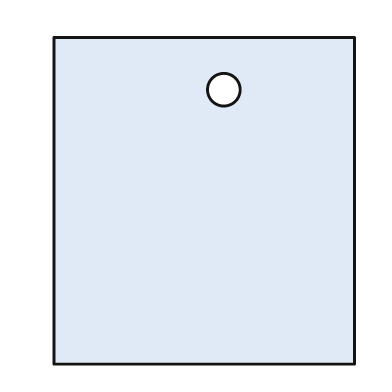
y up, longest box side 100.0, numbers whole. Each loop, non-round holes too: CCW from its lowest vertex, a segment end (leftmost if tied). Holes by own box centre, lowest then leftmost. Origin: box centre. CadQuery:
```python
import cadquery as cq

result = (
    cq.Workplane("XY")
    .moveTo(-46.0, -50.0)
    .lineTo(46.0, -50.0)
    .lineTo(46.0, 50.0)
    .lineTo(-46.0, 50.0)
    .close()
    .moveTo(6.0, 34.0)
    .circle(5.0)
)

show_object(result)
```